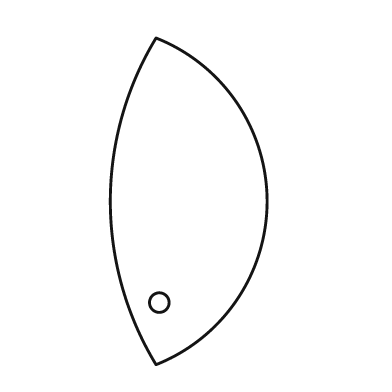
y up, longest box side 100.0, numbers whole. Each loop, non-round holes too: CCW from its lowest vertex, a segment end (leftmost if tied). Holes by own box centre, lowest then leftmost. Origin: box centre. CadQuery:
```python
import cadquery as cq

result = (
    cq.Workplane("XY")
    .moveTo(-10.0, -50.0)
    .threePointArc((24.0, 0.0), (-10.0, 50.0))
    .threePointArc((-24.0, 0.0), (-10.0, -50.0))
    .close()
    .moveTo(-9.0, -31.0)
    .circle(3.0)
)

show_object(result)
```